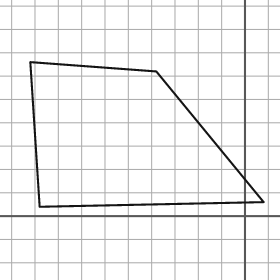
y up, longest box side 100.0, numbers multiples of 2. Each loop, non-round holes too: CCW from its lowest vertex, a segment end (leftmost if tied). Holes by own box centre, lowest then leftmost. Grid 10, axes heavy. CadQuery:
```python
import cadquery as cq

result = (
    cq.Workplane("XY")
    .moveTo(-88.0, 4.0)
    .lineTo(8.0, 6.0)
    .lineTo(-38.0, 62.0)
    .lineTo(-92.0, 66.0)
    .close()
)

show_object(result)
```